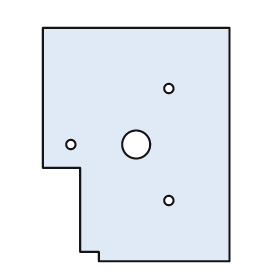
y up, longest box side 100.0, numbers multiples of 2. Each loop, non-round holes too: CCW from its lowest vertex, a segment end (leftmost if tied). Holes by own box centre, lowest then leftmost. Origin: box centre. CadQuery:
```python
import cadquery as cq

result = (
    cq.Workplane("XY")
    .moveTo(-16.0, -50.0)
    .lineTo(40.0, -50.0)
    .lineTo(40.0, 50.0)
    .lineTo(-40.0, 50.0)
    .lineTo(-40.0, -10.0)
    .lineTo(-24.0, -10.0)
    .lineTo(-24.0, -46.0)
    .lineTo(-16.0, -46.0)
    .close()
    .moveTo(14.0, -24.0)
    .circle(2.0)
    .moveTo(-28.0, 0.0)
    .circle(2.0)
    .moveTo(0.0, 0.0)
    .circle(6.0)
    .moveTo(14.0, 24.0)
    .circle(2.0)
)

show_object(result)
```